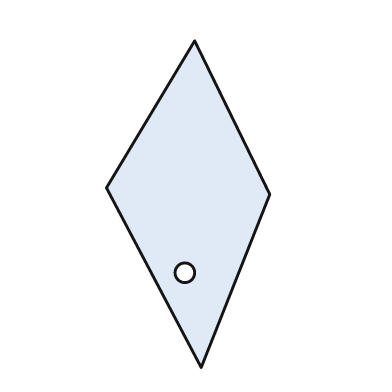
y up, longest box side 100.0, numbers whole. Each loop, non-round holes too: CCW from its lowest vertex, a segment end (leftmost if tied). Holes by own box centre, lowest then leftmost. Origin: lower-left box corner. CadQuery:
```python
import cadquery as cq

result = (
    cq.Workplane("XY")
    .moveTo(29.0, 0.0)
    .lineTo(50.0, 53.0)
    .lineTo(27.0, 100.0)
    .lineTo(0.0, 55.0)
    .close()
    .moveTo(24.0, 29.0)
    .circle(3.0)
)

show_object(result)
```